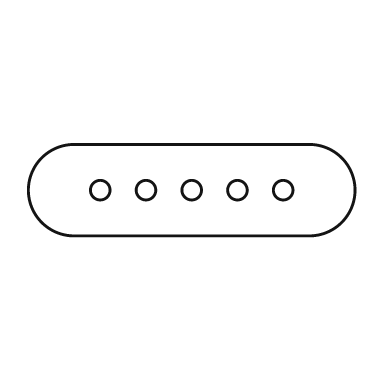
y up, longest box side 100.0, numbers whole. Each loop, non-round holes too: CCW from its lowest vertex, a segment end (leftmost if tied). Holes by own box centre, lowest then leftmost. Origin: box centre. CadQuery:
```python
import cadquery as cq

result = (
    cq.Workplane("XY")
    .moveTo(-36.0, -14.0)
    .lineTo(36.0, -14.0)
    .threePointArc((50.0, 0.0), (36.0, 14.0))
    .lineTo(-36.0, 14.0)
    .threePointArc((-50.0, 0.0), (-36.0, -14.0))
    .close()
    .moveTo(-28.0, 0.0)
    .circle(3.0)
    .moveTo(-14.0, 0.0)
    .circle(3.0)
    .moveTo(0.0, 0.0)
    .circle(3.0)
    .moveTo(14.0, 0.0)
    .circle(3.0)
    .moveTo(28.0, 0.0)
    .circle(3.0)
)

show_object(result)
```